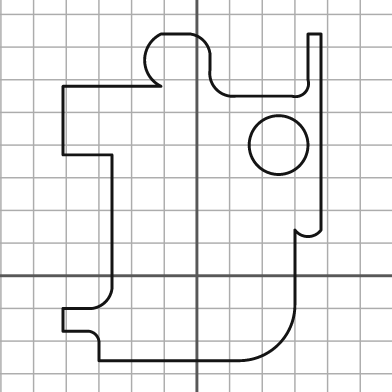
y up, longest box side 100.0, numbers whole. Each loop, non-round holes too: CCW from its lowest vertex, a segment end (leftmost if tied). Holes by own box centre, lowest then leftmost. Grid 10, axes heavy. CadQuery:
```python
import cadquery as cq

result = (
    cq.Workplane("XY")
    .moveTo(-30.0, -26.0)
    .lineTo(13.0, -26.0)
    .threePointArc((25.0, -21.0), (30.0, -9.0))
    .lineTo(30.0, 14.0)
    .threePointArc((34.0, 12.0), (38.0, 14.0))
    .lineTo(38.0, 74.0)
    .lineTo(34.0, 74.0)
    .lineTo(34.0, 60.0)
    .threePointArc((33.0, 56.0), (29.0, 55.0))
    .lineTo(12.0, 55.0)
    .threePointArc((6.0, 57.0), (4.0, 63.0))
    .lineTo(4.0, 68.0)
    .threePointArc((2.0, 72.0), (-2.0, 74.0))
    .lineTo(-11.0, 74.0)
    .threePointArc((-16.0, 66.0), (-11.0, 58.0))
    .lineTo(-41.0, 58.0)
    .lineTo(-41.0, 37.0)
    .lineTo(-26.0, 37.0)
    .lineTo(-26.0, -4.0)
    .threePointArc((-28.0, -8.0), (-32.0, -10.0))
    .lineTo(-41.0, -10.0)
    .lineTo(-41.0, -17.0)
    .lineTo(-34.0, -17.0)
    .threePointArc((-31.0, -18.0), (-30.0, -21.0))
    .close()
    .moveTo(25.0, 40.0)
    .circle(9.0)
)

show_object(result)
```